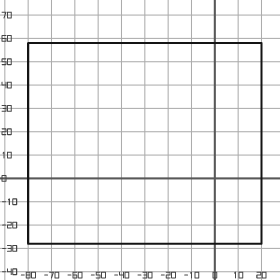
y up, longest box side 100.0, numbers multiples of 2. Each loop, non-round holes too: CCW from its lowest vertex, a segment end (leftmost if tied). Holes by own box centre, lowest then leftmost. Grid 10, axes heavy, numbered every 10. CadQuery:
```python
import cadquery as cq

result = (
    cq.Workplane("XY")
    .moveTo(-80.0, -28.0)
    .lineTo(20.0, -28.0)
    .lineTo(20.0, 58.0)
    .lineTo(-80.0, 58.0)
    .close()
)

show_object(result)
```